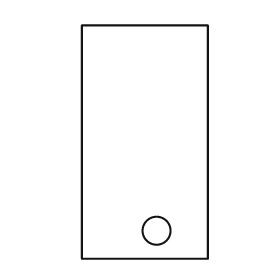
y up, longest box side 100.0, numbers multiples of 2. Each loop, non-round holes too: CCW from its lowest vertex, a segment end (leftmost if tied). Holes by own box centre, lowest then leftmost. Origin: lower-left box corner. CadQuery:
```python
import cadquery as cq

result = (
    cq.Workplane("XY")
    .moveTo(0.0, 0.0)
    .lineTo(54.0, 0.0)
    .lineTo(54.0, 100.0)
    .lineTo(0.0, 100.0)
    .close()
    .moveTo(32.0, 12.0)
    .circle(6.0)
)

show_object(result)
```